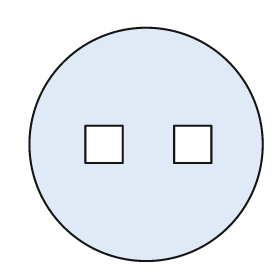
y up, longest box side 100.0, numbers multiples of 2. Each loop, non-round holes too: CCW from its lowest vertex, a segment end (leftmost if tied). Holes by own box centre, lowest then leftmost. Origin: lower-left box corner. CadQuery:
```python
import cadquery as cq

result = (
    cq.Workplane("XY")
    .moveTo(50.0, 50.0)
    .circle(50.0)
    .moveTo(24.0, 42.0)
    .lineTo(40.0, 42.0)
    .lineTo(40.0, 58.0)
    .lineTo(24.0, 58.0)
    .close()
    .moveTo(62.0, 42.0)
    .lineTo(78.0, 42.0)
    .lineTo(78.0, 58.0)
    .lineTo(62.0, 58.0)
    .close()
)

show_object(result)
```